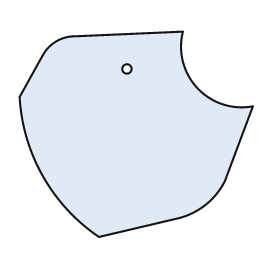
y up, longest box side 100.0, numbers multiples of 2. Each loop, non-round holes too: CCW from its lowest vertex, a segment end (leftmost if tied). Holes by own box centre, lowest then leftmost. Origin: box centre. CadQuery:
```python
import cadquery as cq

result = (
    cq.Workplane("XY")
    .moveTo(-16.0, -44.0)
    .lineTo(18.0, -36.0)
    .threePointArc((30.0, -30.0), (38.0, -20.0))
    .lineTo(50.0, 12.0)
    .threePointArc((26.0, 20.0), (20.0, 44.0))
    .lineTo(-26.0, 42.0)
    .threePointArc((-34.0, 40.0), (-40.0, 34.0))
    .lineTo(-50.0, 16.0)
    .threePointArc((-40.0, -18.0), (-16.0, -44.0))
    .close()
    .moveTo(-4.0, 28.0)
    .circle(2.0)
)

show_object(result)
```